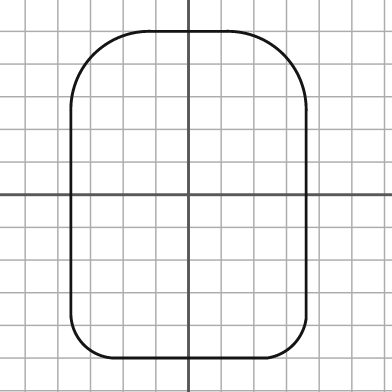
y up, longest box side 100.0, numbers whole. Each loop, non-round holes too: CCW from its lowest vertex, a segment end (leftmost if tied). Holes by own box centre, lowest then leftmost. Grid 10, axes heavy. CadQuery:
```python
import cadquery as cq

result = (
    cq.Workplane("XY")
    .moveTo(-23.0, -50.0)
    .lineTo(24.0, -50.0)
    .threePointArc((32.0, -46.0), (36.0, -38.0))
    .lineTo(36.0, 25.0)
    .threePointArc((29.0, 43.0), (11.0, 50.0))
    .lineTo(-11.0, 50.0)
    .threePointArc((-29.0, 43.0), (-36.0, 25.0))
    .lineTo(-36.0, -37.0)
    .threePointArc((-32.0, -46.0), (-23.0, -50.0))
    .close()
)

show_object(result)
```